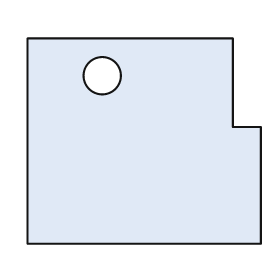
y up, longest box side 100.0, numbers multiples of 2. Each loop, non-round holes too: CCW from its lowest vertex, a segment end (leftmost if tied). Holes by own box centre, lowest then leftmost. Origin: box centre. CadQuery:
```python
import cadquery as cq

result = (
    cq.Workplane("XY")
    .moveTo(-50.0, -44.0)
    .lineTo(50.0, -44.0)
    .lineTo(50.0, 6.0)
    .lineTo(38.0, 6.0)
    .lineTo(38.0, 44.0)
    .lineTo(-50.0, 44.0)
    .close()
    .moveTo(-18.0, 28.0)
    .circle(8.0)
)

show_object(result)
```